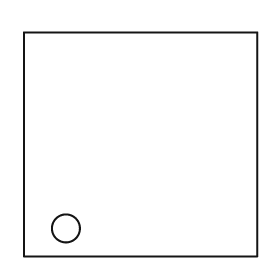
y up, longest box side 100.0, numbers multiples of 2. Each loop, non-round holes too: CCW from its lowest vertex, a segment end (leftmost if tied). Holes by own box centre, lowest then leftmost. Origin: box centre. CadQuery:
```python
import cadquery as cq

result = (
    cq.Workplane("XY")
    .moveTo(-50.0, -48.0)
    .lineTo(50.0, -48.0)
    .lineTo(50.0, 48.0)
    .lineTo(-50.0, 48.0)
    .close()
    .moveTo(-32.0, -36.0)
    .circle(6.0)
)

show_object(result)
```